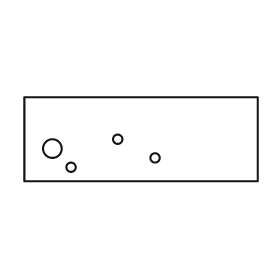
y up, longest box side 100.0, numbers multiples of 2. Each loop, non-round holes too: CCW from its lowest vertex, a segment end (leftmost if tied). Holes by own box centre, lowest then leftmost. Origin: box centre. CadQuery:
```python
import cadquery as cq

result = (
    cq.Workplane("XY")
    .moveTo(-50.0, -18.0)
    .lineTo(50.0, -18.0)
    .lineTo(50.0, 18.0)
    .lineTo(-50.0, 18.0)
    .close()
    .moveTo(-30.0, -12.0)
    .circle(2.0)
    .moveTo(6.0, -8.0)
    .circle(2.0)
    .moveTo(-38.0, -4.0)
    .circle(4.0)
    .moveTo(-10.0, 0.0)
    .circle(2.0)
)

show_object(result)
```